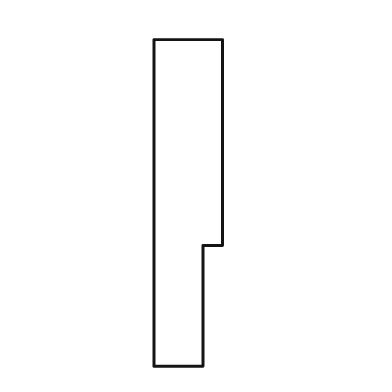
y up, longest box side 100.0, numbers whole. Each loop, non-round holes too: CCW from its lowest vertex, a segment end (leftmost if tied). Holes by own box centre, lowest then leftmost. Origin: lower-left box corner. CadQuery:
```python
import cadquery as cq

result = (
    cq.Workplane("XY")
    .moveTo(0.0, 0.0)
    .lineTo(15.0, 0.0)
    .lineTo(15.0, 37.0)
    .lineTo(21.0, 37.0)
    .lineTo(21.0, 100.0)
    .lineTo(0.0, 100.0)
    .close()
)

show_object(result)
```